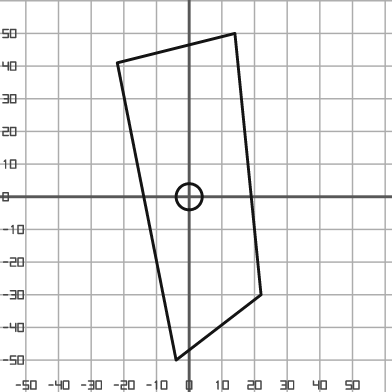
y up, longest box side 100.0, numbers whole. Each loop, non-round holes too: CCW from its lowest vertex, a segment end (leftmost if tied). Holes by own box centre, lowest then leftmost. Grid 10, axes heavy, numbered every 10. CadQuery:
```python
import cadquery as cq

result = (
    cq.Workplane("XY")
    .moveTo(-4.0, -50.0)
    .lineTo(22.0, -30.0)
    .lineTo(14.0, 50.0)
    .lineTo(-22.0, 41.0)
    .close()
    .moveTo(0.0, 0.0)
    .circle(4.0)
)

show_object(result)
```